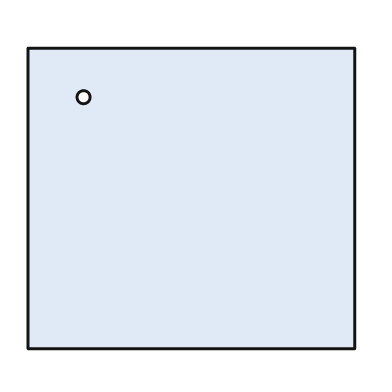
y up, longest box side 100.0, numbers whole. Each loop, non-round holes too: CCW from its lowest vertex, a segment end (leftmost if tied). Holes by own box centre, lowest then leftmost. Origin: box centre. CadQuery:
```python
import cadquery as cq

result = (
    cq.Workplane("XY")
    .moveTo(-50.0, -46.0)
    .lineTo(50.0, -46.0)
    .lineTo(50.0, 46.0)
    .lineTo(-50.0, 46.0)
    .close()
    .moveTo(-33.0, 31.0)
    .circle(2.0)
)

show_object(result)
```